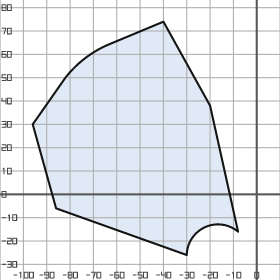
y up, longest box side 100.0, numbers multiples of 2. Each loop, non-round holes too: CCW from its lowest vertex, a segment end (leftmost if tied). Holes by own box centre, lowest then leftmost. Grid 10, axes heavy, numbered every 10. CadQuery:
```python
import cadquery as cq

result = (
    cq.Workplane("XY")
    .moveTo(-30.0, -26.0)
    .threePointArc((-22.0, -14.0), (-8.0, -16.0))
    .lineTo(-20.0, 38.0)
    .lineTo(-40.0, 74.0)
    .lineTo(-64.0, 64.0)
    .threePointArc((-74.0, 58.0), (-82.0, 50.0))
    .lineTo(-96.0, 30.0)
    .lineTo(-86.0, -6.0)
    .close()
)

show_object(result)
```